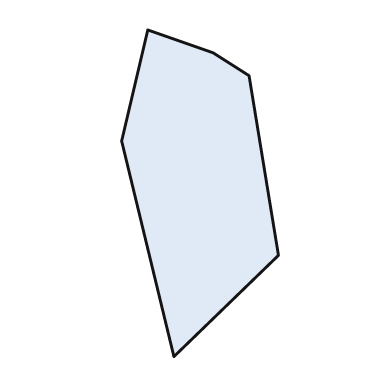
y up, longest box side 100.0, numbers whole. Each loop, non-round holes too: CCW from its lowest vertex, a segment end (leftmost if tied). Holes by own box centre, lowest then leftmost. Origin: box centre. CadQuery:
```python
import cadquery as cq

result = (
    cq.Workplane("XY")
    .moveTo(-8.0, -50.0)
    .lineTo(24.0, -19.0)
    .lineTo(15.0, 36.0)
    .lineTo(4.0, 43.0)
    .lineTo(-16.0, 50.0)
    .lineTo(-24.0, 16.0)
    .close()
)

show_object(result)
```